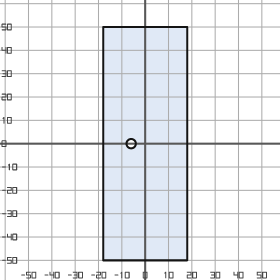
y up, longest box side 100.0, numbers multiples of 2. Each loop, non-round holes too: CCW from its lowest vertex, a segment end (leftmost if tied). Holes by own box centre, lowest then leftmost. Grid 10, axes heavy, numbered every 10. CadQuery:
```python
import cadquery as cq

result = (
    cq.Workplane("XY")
    .moveTo(-18.0, -50.0)
    .lineTo(18.0, -50.0)
    .lineTo(18.0, 50.0)
    .lineTo(-18.0, 50.0)
    .close()
    .moveTo(-6.0, 0.0)
    .circle(2.0)
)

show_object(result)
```